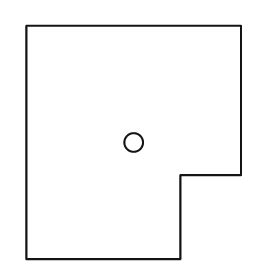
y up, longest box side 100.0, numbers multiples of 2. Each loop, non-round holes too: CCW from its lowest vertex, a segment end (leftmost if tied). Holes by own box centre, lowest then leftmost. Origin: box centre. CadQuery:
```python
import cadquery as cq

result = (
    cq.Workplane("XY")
    .moveTo(-46.0, -50.0)
    .lineTo(20.0, -50.0)
    .lineTo(20.0, -14.0)
    .lineTo(46.0, -14.0)
    .lineTo(46.0, 50.0)
    .lineTo(-46.0, 50.0)
    .close()
    .moveTo(0.0, 0.0)
    .circle(4.0)
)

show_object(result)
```